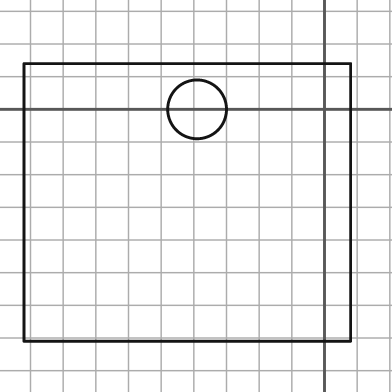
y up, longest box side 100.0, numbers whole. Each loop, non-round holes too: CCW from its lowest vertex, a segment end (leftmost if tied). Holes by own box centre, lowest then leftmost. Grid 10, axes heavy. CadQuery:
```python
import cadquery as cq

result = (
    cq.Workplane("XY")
    .moveTo(-92.0, -71.0)
    .lineTo(8.0, -71.0)
    .lineTo(8.0, 14.0)
    .lineTo(-92.0, 14.0)
    .close()
    .moveTo(-39.0, 0.0)
    .circle(9.0)
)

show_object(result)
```